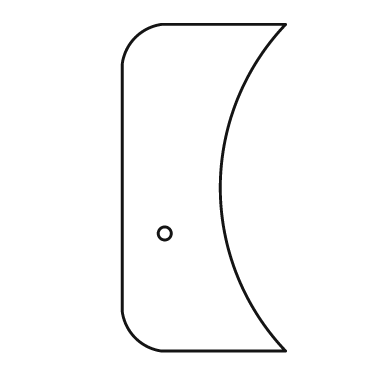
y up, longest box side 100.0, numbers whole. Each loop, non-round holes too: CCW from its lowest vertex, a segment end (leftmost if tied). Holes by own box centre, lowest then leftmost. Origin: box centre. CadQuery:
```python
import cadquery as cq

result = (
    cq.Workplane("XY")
    .moveTo(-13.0, -50.0)
    .lineTo(25.0, -50.0)
    .threePointArc((5.0, 0.0), (25.0, 50.0))
    .lineTo(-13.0, 50.0)
    .threePointArc((-21.0, 46.0), (-25.0, 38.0))
    .lineTo(-25.0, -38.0)
    .threePointArc((-21.0, -46.0), (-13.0, -50.0))
    .close()
    .moveTo(-12.0, -14.0)
    .circle(2.0)
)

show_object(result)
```